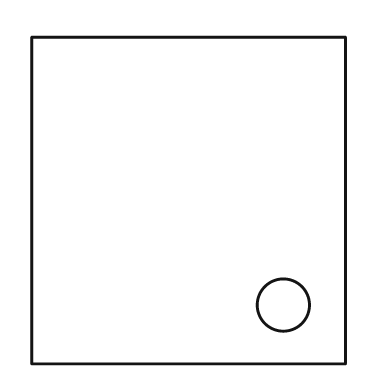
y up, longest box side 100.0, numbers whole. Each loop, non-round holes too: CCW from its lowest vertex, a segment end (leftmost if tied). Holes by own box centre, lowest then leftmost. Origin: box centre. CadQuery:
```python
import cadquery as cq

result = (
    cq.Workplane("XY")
    .moveTo(-48.0, -50.0)
    .lineTo(48.0, -50.0)
    .lineTo(48.0, 50.0)
    .lineTo(-48.0, 50.0)
    .close()
    .moveTo(29.0, -32.0)
    .circle(8.0)
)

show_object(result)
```